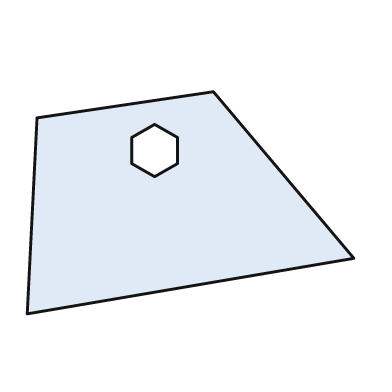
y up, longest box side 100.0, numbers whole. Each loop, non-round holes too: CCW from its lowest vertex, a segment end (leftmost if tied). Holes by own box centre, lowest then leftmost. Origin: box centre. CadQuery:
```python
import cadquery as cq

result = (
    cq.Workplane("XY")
    .moveTo(-50.0, -34.0)
    .lineTo(50.0, -17.0)
    .lineTo(7.0, 34.0)
    .lineTo(-47.0, 26.0)
    .close()
    .moveTo(-11.0, 8.0)
    .lineTo(-4.0, 12.0)
    .lineTo(-4.0, 20.0)
    .lineTo(-11.0, 24.0)
    .lineTo(-18.0, 20.0)
    .lineTo(-18.0, 12.0)
    .close()
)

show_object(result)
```